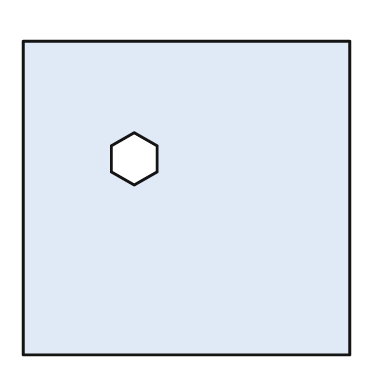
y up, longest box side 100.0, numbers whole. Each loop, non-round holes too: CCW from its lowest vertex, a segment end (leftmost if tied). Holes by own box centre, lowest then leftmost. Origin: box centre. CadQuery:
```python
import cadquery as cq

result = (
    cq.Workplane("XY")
    .moveTo(-50.0, -48.0)
    .lineTo(50.0, -48.0)
    .lineTo(50.0, 48.0)
    .lineTo(-50.0, 48.0)
    .close()
    .moveTo(-16.0, 4.0)
    .lineTo(-9.0, 8.0)
    .lineTo(-9.0, 16.0)
    .lineTo(-16.0, 20.0)
    .lineTo(-23.0, 16.0)
    .lineTo(-23.0, 8.0)
    .close()
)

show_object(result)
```